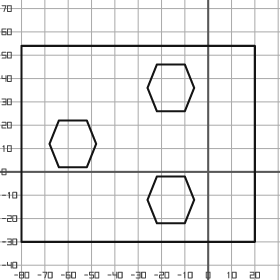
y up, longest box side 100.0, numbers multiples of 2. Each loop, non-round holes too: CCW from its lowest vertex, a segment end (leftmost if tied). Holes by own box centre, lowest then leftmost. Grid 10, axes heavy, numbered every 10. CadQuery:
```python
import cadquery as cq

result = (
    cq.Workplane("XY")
    .moveTo(-80.0, -30.0)
    .lineTo(20.0, -30.0)
    .lineTo(20.0, 54.0)
    .lineTo(-80.0, 54.0)
    .close()
    .moveTo(-22.0, -22.0)
    .lineTo(-10.0, -22.0)
    .lineTo(-6.0, -12.0)
    .lineTo(-10.0, -2.0)
    .lineTo(-22.0, -2.0)
    .lineTo(-26.0, -12.0)
    .close()
    .moveTo(-64.0, 2.0)
    .lineTo(-52.0, 2.0)
    .lineTo(-48.0, 12.0)
    .lineTo(-52.0, 22.0)
    .lineTo(-64.0, 22.0)
    .lineTo(-68.0, 12.0)
    .close()
    .moveTo(-22.0, 26.0)
    .lineTo(-10.0, 26.0)
    .lineTo(-6.0, 36.0)
    .lineTo(-10.0, 46.0)
    .lineTo(-22.0, 46.0)
    .lineTo(-26.0, 36.0)
    .close()
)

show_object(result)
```